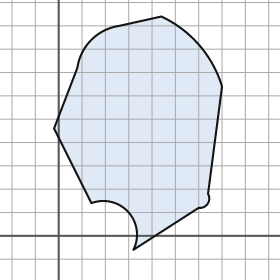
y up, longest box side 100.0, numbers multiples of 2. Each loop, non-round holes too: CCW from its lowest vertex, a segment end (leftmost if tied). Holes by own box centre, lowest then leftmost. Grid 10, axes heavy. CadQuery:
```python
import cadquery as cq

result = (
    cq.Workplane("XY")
    .moveTo(32.0, -6.0)
    .lineTo(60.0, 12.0)
    .threePointArc((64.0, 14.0), (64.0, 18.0))
    .lineTo(70.0, 64.0)
    .threePointArc((60.0, 82.0), (44.0, 94.0))
    .lineTo(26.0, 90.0)
    .threePointArc((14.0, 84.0), (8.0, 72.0))
    .lineTo(-2.0, 46.0)
    .lineTo(14.0, 14.0)
    .threePointArc((30.0, 10.0), (32.0, -6.0))
    .close()
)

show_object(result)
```